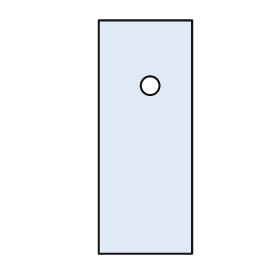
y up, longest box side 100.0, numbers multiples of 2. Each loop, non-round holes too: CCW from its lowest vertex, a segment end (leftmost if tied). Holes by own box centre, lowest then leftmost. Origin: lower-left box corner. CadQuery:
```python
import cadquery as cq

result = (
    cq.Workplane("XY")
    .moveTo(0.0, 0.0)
    .lineTo(40.0, 0.0)
    .lineTo(40.0, 100.0)
    .lineTo(0.0, 100.0)
    .close()
    .moveTo(22.0, 72.0)
    .circle(4.0)
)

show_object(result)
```